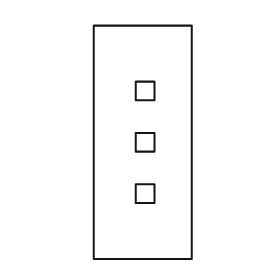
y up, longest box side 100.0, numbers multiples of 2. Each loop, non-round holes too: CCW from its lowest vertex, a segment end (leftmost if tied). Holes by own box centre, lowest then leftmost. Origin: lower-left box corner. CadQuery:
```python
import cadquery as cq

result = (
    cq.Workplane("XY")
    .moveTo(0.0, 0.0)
    .lineTo(42.0, 0.0)
    .lineTo(42.0, 100.0)
    .lineTo(0.0, 100.0)
    .close()
    .moveTo(18.0, 24.0)
    .lineTo(26.0, 24.0)
    .lineTo(26.0, 32.0)
    .lineTo(18.0, 32.0)
    .close()
    .moveTo(18.0, 46.0)
    .lineTo(26.0, 46.0)
    .lineTo(26.0, 54.0)
    .lineTo(18.0, 54.0)
    .close()
    .moveTo(18.0, 68.0)
    .lineTo(26.0, 68.0)
    .lineTo(26.0, 76.0)
    .lineTo(18.0, 76.0)
    .close()
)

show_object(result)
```